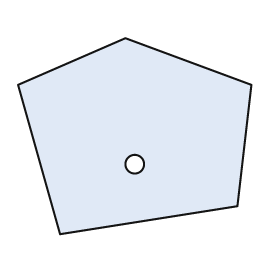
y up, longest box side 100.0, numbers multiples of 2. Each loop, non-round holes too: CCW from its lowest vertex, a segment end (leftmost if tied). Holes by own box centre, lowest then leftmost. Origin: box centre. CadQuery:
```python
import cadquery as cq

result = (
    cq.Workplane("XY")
    .moveTo(-32.0, -42.0)
    .lineTo(44.0, -30.0)
    .lineTo(50.0, 22.0)
    .lineTo(-4.0, 42.0)
    .lineTo(-50.0, 22.0)
    .close()
    .moveTo(0.0, -12.0)
    .circle(4.0)
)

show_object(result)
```